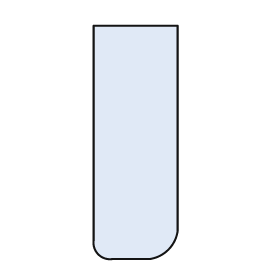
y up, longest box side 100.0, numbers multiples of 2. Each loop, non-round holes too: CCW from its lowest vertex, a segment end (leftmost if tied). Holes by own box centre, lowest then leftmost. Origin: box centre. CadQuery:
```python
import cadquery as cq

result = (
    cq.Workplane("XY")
    .moveTo(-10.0, -50.0)
    .lineTo(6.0, -50.0)
    .threePointArc((14.0, -46.0), (18.0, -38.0))
    .lineTo(18.0, 50.0)
    .lineTo(-18.0, 50.0)
    .lineTo(-18.0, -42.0)
    .threePointArc((-16.0, -48.0), (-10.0, -50.0))
    .close()
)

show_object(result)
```